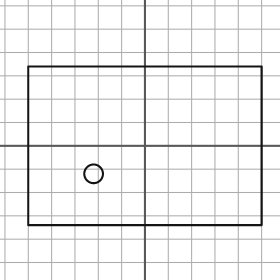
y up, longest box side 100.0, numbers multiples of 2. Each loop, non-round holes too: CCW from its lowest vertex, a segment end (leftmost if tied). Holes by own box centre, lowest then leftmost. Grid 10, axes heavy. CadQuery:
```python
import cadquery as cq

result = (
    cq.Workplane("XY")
    .moveTo(-50.0, -34.0)
    .lineTo(50.0, -34.0)
    .lineTo(50.0, 34.0)
    .lineTo(-50.0, 34.0)
    .close()
    .moveTo(-22.0, -12.0)
    .circle(4.0)
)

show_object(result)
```